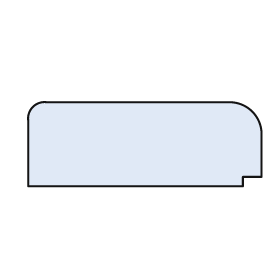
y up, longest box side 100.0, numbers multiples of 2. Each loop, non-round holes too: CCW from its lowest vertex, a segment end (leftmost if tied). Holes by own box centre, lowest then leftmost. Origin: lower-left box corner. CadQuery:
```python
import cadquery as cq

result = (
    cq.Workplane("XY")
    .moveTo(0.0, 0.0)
    .lineTo(92.0, 0.0)
    .lineTo(92.0, 4.0)
    .lineTo(100.0, 4.0)
    .lineTo(100.0, 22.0)
    .threePointArc((96.0, 32.0), (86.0, 36.0))
    .lineTo(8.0, 36.0)
    .threePointArc((2.0, 34.0), (0.0, 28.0))
    .close()
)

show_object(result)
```